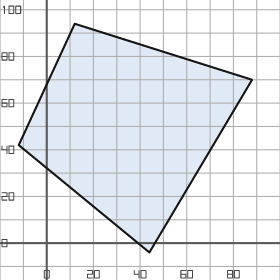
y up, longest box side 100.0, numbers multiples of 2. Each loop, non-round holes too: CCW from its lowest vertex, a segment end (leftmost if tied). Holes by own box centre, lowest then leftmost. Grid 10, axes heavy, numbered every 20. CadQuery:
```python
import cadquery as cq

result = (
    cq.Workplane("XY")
    .moveTo(44.0, -4.0)
    .lineTo(88.0, 70.0)
    .lineTo(12.0, 94.0)
    .lineTo(-12.0, 42.0)
    .close()
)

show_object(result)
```